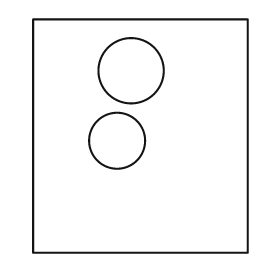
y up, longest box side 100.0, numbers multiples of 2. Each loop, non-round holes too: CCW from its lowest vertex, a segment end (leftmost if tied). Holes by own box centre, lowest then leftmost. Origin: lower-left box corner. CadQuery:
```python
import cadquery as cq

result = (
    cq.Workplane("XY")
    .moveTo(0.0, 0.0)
    .lineTo(92.0, 0.0)
    .lineTo(92.0, 100.0)
    .lineTo(0.0, 100.0)
    .close()
    .moveTo(36.0, 48.0)
    .circle(12.0)
    .moveTo(42.0, 78.0)
    .circle(14.0)
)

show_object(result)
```